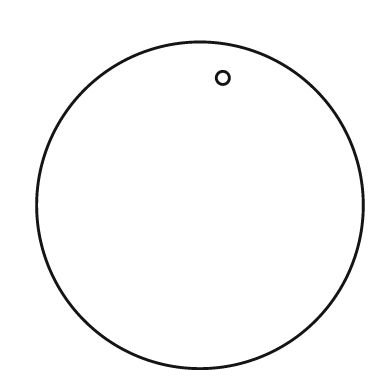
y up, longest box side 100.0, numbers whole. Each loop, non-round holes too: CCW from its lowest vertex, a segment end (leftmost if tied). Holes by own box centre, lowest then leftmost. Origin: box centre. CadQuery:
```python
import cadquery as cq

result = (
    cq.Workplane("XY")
    .moveTo(0.0, 0.0)
    .circle(50.0)
    .moveTo(7.0, 39.0)
    .circle(2.0)
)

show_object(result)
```